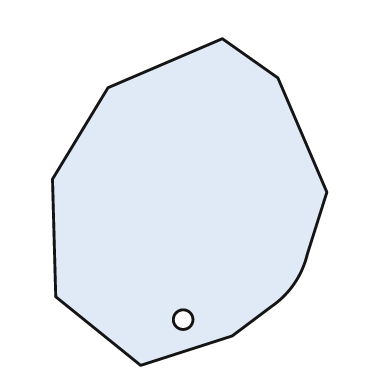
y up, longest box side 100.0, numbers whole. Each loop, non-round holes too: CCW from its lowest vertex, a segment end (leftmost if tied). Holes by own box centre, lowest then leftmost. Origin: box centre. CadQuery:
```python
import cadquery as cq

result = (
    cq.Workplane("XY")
    .moveTo(-15.0, -50.0)
    .lineTo(13.0, -41.0)
    .lineTo(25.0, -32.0)
    .threePointArc((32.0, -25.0), (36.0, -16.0))
    .lineTo(42.0, 3.0)
    .lineTo(27.0, 38.0)
    .lineTo(10.0, 50.0)
    .lineTo(-25.0, 35.0)
    .lineTo(-42.0, 7.0)
    .lineTo(-41.0, -29.0)
    .close()
    .moveTo(-2.0, -36.0)
    .circle(3.0)
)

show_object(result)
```